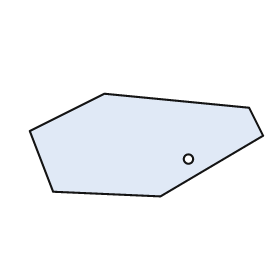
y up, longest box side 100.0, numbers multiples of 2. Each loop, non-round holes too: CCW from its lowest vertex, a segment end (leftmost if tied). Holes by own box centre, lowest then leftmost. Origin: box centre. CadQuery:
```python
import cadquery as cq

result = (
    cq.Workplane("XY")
    .moveTo(6.0, -22.0)
    .lineTo(50.0, 4.0)
    .lineTo(44.0, 16.0)
    .lineTo(-18.0, 22.0)
    .lineTo(-50.0, 6.0)
    .lineTo(-40.0, -20.0)
    .close()
    .moveTo(18.0, -6.0)
    .circle(2.0)
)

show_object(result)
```